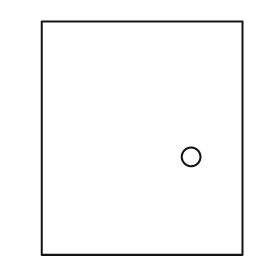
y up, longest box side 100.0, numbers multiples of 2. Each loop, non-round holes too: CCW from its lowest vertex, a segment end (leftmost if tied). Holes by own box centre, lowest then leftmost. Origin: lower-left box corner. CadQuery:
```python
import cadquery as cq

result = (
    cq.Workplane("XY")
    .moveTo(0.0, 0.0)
    .lineTo(86.0, 0.0)
    .lineTo(86.0, 100.0)
    .lineTo(0.0, 100.0)
    .close()
    .moveTo(64.0, 42.0)
    .circle(4.0)
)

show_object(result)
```